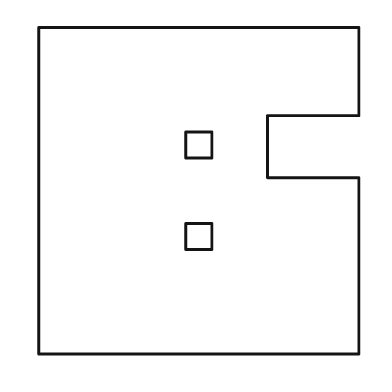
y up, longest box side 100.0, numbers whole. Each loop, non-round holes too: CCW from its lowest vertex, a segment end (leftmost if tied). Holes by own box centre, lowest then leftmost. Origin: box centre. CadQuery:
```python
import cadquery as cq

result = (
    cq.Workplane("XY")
    .moveTo(-49.0, -50.0)
    .lineTo(49.0, -50.0)
    .lineTo(49.0, 4.0)
    .lineTo(21.0, 4.0)
    .lineTo(21.0, 23.0)
    .lineTo(49.0, 23.0)
    .lineTo(49.0, 50.0)
    .lineTo(-49.0, 50.0)
    .close()
    .moveTo(-4.0, -18.0)
    .lineTo(4.0, -18.0)
    .lineTo(4.0, -10.0)
    .lineTo(-4.0, -10.0)
    .close()
    .moveTo(-4.0, 10.0)
    .lineTo(4.0, 10.0)
    .lineTo(4.0, 18.0)
    .lineTo(-4.0, 18.0)
    .close()
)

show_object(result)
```